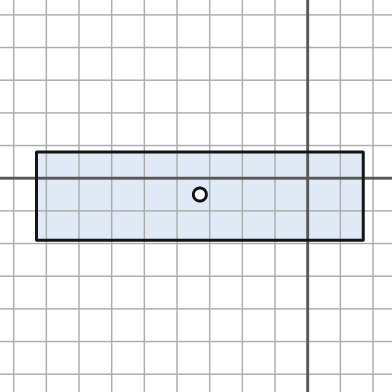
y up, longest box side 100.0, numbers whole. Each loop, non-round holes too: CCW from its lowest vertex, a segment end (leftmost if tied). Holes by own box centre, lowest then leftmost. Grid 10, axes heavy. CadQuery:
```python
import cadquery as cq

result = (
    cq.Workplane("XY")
    .moveTo(-83.0, -19.0)
    .lineTo(17.0, -19.0)
    .lineTo(17.0, 8.0)
    .lineTo(-83.0, 8.0)
    .close()
    .moveTo(-33.0, -5.0)
    .circle(2.0)
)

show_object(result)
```